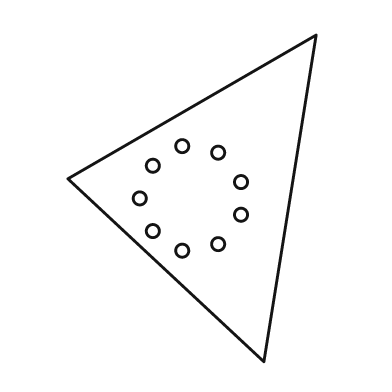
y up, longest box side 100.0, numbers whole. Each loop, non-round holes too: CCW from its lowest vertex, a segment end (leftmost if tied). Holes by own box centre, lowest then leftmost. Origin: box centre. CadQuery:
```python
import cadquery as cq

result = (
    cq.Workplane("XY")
    .moveTo(22.0, -50.0)
    .lineTo(38.0, 50.0)
    .lineTo(-38.0, 6.0)
    .close()
    .moveTo(-3.0, -16.0)
    .circle(2.0)
    .moveTo(8.0, -14.0)
    .circle(2.0)
    .moveTo(-12.0, -10.0)
    .circle(2.0)
    .moveTo(15.0, -5.0)
    .circle(2.0)
    .moveTo(-16.0, 0.0)
    .circle(2.0)
    .moveTo(15.0, 5.0)
    .circle(2.0)
    .moveTo(-12.0, 10.0)
    .circle(2.0)
    .moveTo(8.0, 14.0)
    .circle(2.0)
    .moveTo(-3.0, 16.0)
    .circle(2.0)
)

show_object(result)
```